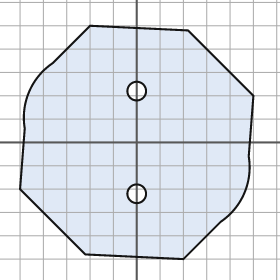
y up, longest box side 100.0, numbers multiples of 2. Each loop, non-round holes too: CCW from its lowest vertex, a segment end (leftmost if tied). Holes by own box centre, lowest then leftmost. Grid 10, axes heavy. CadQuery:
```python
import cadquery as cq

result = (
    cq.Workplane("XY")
    .moveTo(20.0, -50.0)
    .lineTo(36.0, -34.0)
    .threePointArc((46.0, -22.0), (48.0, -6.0))
    .lineTo(50.0, 20.0)
    .lineTo(22.0, 48.0)
    .lineTo(-20.0, 50.0)
    .lineTo(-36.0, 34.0)
    .threePointArc((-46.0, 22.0), (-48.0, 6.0))
    .lineTo(-50.0, -20.0)
    .lineTo(-22.0, -48.0)
    .close()
    .moveTo(0.0, -22.0)
    .circle(4.0)
    .moveTo(0.0, 22.0)
    .circle(4.0)
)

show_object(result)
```